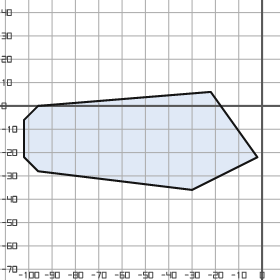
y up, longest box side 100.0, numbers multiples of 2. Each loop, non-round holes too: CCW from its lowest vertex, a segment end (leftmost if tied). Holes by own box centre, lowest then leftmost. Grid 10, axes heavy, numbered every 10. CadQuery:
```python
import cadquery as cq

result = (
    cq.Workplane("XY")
    .moveTo(-30.0, -36.0)
    .lineTo(-2.0, -22.0)
    .lineTo(-22.0, 6.0)
    .lineTo(-96.0, 0.0)
    .lineTo(-102.0, -6.0)
    .lineTo(-102.0, -22.0)
    .lineTo(-96.0, -28.0)
    .close()
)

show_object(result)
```